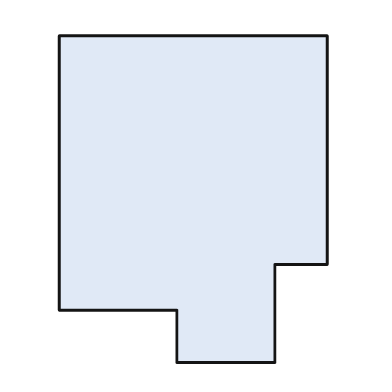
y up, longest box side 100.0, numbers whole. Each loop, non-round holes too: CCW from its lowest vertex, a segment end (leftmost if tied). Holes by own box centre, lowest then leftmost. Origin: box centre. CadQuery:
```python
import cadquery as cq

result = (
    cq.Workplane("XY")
    .moveTo(-5.0, -50.0)
    .lineTo(25.0, -50.0)
    .lineTo(25.0, -20.0)
    .lineTo(41.0, -20.0)
    .lineTo(41.0, 50.0)
    .lineTo(-41.0, 50.0)
    .lineTo(-41.0, -34.0)
    .lineTo(-5.0, -34.0)
    .close()
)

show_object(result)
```